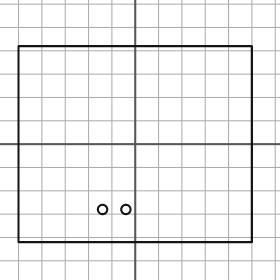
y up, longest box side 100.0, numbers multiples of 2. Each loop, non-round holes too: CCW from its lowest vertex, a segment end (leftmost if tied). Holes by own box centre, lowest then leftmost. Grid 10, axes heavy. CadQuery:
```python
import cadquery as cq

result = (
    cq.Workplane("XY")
    .moveTo(-50.0, -42.0)
    .lineTo(50.0, -42.0)
    .lineTo(50.0, 42.0)
    .lineTo(-50.0, 42.0)
    .close()
    .moveTo(-14.0, -28.0)
    .circle(2.0)
    .moveTo(-4.0, -28.0)
    .circle(2.0)
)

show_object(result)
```